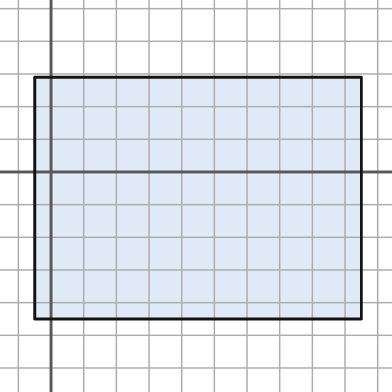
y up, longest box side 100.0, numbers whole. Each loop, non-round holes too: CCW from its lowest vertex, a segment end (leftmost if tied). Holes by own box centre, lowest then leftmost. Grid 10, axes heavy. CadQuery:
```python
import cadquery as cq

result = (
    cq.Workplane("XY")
    .moveTo(-5.0, -45.0)
    .lineTo(95.0, -45.0)
    .lineTo(95.0, 29.0)
    .lineTo(-5.0, 29.0)
    .close()
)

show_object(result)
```